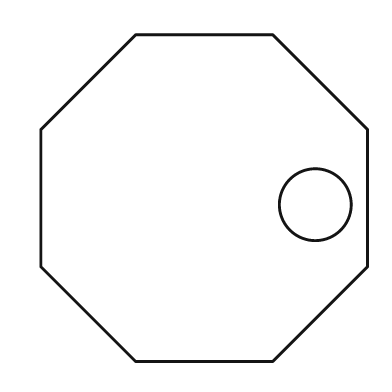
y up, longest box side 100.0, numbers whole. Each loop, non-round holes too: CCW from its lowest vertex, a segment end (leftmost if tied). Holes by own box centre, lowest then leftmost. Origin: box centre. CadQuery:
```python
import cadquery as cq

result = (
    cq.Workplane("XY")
    .moveTo(-21.0, -50.0)
    .lineTo(21.0, -50.0)
    .lineTo(50.0, -21.0)
    .lineTo(50.0, 21.0)
    .lineTo(21.0, 50.0)
    .lineTo(-21.0, 50.0)
    .lineTo(-50.0, 21.0)
    .lineTo(-50.0, -21.0)
    .close()
    .moveTo(34.0, -2.0)
    .circle(11.0)
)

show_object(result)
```